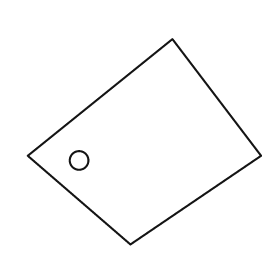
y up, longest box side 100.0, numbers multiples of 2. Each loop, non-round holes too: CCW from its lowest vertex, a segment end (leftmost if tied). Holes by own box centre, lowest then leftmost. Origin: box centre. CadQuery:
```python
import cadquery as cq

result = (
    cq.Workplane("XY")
    .moveTo(-6.0, -44.0)
    .lineTo(50.0, -6.0)
    .lineTo(12.0, 44.0)
    .lineTo(-50.0, -6.0)
    .close()
    .moveTo(-28.0, -8.0)
    .circle(4.0)
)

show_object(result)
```